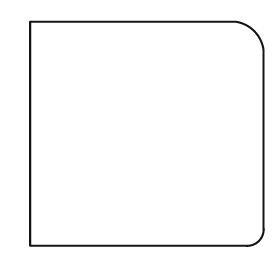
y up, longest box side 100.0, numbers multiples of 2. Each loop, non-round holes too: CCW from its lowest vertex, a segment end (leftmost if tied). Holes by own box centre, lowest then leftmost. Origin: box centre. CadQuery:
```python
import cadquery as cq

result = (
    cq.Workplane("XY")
    .moveTo(-50.0, -48.0)
    .lineTo(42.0, -48.0)
    .threePointArc((48.0, -46.0), (50.0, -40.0))
    .lineTo(50.0, 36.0)
    .threePointArc((46.0, 44.0), (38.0, 48.0))
    .lineTo(-50.0, 48.0)
    .close()
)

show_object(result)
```